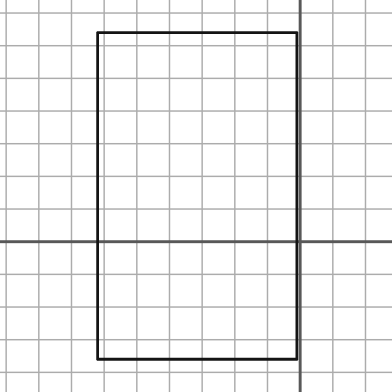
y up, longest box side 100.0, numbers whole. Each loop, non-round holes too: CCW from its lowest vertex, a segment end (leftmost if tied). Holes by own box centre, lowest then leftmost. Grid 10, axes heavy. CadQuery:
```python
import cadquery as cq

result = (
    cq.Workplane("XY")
    .moveTo(-62.0, -36.0)
    .lineTo(-1.0, -36.0)
    .lineTo(-1.0, 64.0)
    .lineTo(-62.0, 64.0)
    .close()
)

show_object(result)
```